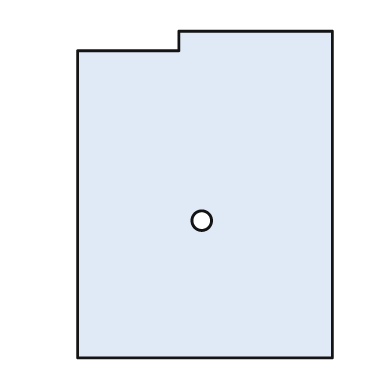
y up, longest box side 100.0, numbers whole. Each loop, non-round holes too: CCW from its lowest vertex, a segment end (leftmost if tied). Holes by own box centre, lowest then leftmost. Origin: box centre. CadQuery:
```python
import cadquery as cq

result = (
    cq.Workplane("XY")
    .moveTo(-39.0, -50.0)
    .lineTo(39.0, -50.0)
    .lineTo(39.0, 50.0)
    .lineTo(-8.0, 50.0)
    .lineTo(-8.0, 44.0)
    .lineTo(-39.0, 44.0)
    .close()
    .moveTo(-1.0, -8.0)
    .circle(3.0)
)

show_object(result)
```